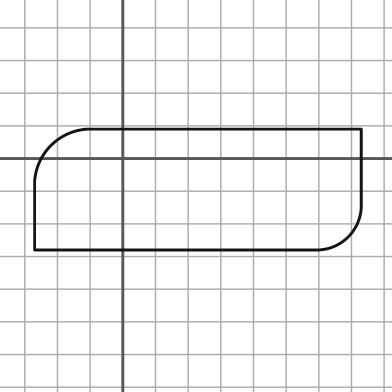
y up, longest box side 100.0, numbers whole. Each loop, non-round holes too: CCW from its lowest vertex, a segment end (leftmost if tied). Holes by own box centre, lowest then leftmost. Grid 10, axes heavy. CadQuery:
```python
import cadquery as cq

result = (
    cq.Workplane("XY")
    .moveTo(-27.0, -28.0)
    .lineTo(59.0, -28.0)
    .threePointArc((69.0, -24.0), (73.0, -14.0))
    .lineTo(73.0, 9.0)
    .lineTo(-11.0, 9.0)
    .threePointArc((-22.0, 4.0), (-27.0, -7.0))
    .close()
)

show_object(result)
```